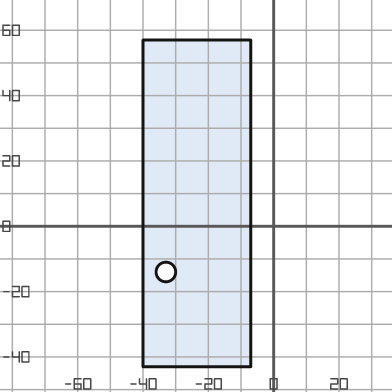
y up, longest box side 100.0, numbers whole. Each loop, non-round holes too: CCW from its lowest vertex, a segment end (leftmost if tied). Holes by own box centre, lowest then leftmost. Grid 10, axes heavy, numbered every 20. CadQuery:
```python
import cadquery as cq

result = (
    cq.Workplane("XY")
    .moveTo(-40.0, -43.0)
    .lineTo(-7.0, -43.0)
    .lineTo(-7.0, 57.0)
    .lineTo(-40.0, 57.0)
    .close()
    .moveTo(-33.0, -14.0)
    .circle(3.0)
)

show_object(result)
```